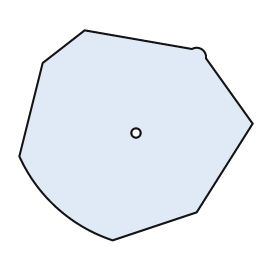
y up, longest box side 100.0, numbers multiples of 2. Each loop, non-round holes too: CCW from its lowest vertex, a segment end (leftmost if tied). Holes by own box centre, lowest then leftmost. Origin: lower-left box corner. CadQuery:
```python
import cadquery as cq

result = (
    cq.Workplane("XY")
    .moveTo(40.0, 0.0)
    .lineTo(76.0, 12.0)
    .lineTo(100.0, 50.0)
    .lineTo(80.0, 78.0)
    .threePointArc((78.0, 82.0), (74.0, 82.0))
    .lineTo(28.0, 90.0)
    .lineTo(10.0, 76.0)
    .lineTo(0.0, 36.0)
    .threePointArc((16.0, 14.0), (40.0, 0.0))
    .close()
    .moveTo(50.0, 46.0)
    .circle(2.0)
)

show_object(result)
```